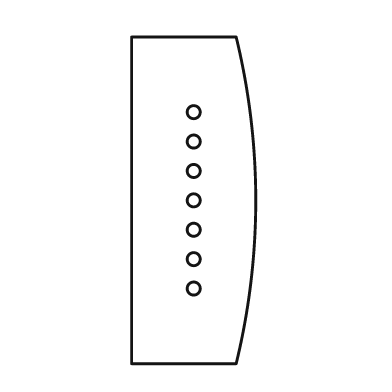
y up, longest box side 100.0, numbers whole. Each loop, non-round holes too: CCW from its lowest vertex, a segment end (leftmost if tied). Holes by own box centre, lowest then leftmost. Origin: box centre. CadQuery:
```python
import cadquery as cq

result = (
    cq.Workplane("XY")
    .moveTo(-19.0, -50.0)
    .lineTo(13.0, -50.0)
    .threePointArc((19.0, 0.0), (13.0, 50.0))
    .lineTo(-19.0, 50.0)
    .close()
    .moveTo(0.0, -27.0)
    .circle(2.0)
    .moveTo(0.0, -18.0)
    .circle(2.0)
    .moveTo(0.0, -9.0)
    .circle(2.0)
    .moveTo(0.0, 0.0)
    .circle(2.0)
    .moveTo(0.0, 9.0)
    .circle(2.0)
    .moveTo(0.0, 18.0)
    .circle(2.0)
    .moveTo(0.0, 27.0)
    .circle(2.0)
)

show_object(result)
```